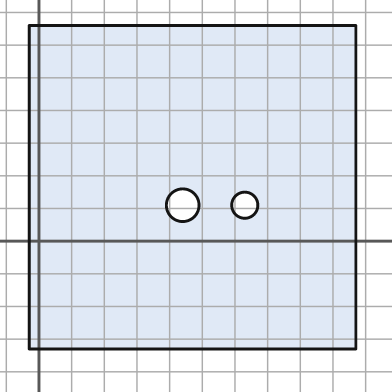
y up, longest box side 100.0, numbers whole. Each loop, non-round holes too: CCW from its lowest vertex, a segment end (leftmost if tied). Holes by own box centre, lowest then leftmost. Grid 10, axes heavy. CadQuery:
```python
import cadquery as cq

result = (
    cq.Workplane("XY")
    .moveTo(-3.0, -33.0)
    .lineTo(97.0, -33.0)
    .lineTo(97.0, 66.0)
    .lineTo(-3.0, 66.0)
    .close()
    .moveTo(44.0, 11.0)
    .circle(5.0)
    .moveTo(63.0, 11.0)
    .circle(4.0)
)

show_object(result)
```